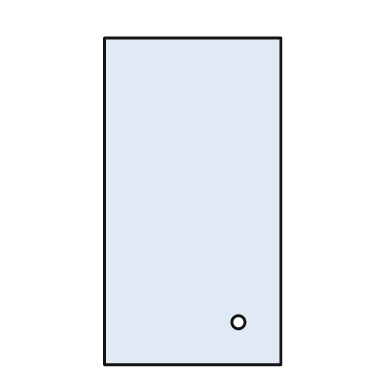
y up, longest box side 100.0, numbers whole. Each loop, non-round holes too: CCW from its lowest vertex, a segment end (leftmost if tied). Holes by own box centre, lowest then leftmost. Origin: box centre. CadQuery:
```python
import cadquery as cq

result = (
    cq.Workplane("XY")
    .moveTo(-27.0, -50.0)
    .lineTo(27.0, -50.0)
    .lineTo(27.0, 50.0)
    .lineTo(-27.0, 50.0)
    .close()
    .moveTo(14.0, -37.0)
    .circle(2.0)
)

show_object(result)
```